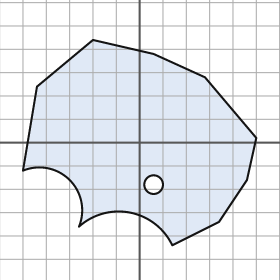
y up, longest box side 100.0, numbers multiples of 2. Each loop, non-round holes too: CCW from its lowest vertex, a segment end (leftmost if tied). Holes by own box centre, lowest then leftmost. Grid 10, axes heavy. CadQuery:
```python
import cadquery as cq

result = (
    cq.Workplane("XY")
    .moveTo(14.0, -44.0)
    .lineTo(34.0, -34.0)
    .lineTo(46.0, -16.0)
    .lineTo(50.0, 2.0)
    .lineTo(28.0, 28.0)
    .lineTo(6.0, 38.0)
    .lineTo(-20.0, 44.0)
    .lineTo(-44.0, 24.0)
    .lineTo(-50.0, -12.0)
    .threePointArc((-30.0, -16.0), (-26.0, -36.0))
    .threePointArc((-4.0, -30.0), (14.0, -44.0))
    .close()
    .moveTo(6.0, -18.0)
    .circle(4.0)
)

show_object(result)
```